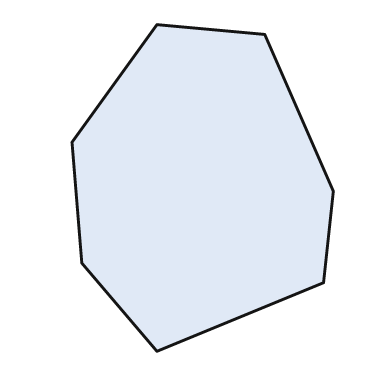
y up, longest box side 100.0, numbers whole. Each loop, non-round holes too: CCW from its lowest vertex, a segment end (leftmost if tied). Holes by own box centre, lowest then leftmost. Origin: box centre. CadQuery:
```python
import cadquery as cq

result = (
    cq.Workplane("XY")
    .moveTo(-14.0, -50.0)
    .lineTo(37.0, -29.0)
    .lineTo(40.0, -1.0)
    .lineTo(19.0, 47.0)
    .lineTo(-14.0, 50.0)
    .lineTo(-40.0, 14.0)
    .lineTo(-37.0, -23.0)
    .close()
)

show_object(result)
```